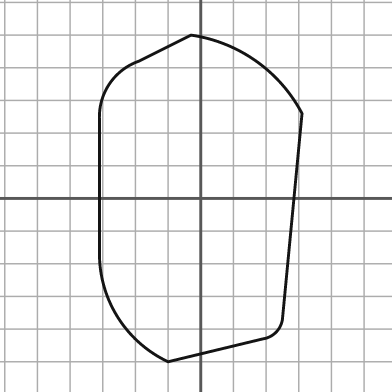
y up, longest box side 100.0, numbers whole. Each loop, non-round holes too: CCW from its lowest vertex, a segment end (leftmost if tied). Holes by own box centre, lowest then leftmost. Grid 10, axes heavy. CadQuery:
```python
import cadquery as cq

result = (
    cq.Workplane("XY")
    .moveTo(-10.0, -50.0)
    .lineTo(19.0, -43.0)
    .threePointArc((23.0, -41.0), (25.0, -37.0))
    .lineTo(31.0, 26.0)
    .threePointArc((17.0, 42.0), (-3.0, 50.0))
    .lineTo(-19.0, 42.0)
    .threePointArc((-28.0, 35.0), (-31.0, 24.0))
    .lineTo(-31.0, -18.0)
    .threePointArc((-25.0, -37.0), (-10.0, -50.0))
    .close()
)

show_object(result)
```